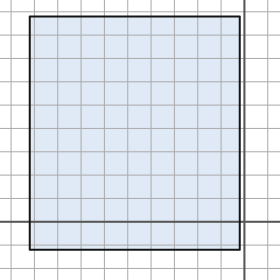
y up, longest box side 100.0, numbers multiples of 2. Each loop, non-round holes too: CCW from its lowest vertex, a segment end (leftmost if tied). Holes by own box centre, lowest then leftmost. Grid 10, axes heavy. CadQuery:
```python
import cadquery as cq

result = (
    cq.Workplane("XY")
    .moveTo(-92.0, -12.0)
    .lineTo(-2.0, -12.0)
    .lineTo(-2.0, 88.0)
    .lineTo(-92.0, 88.0)
    .close()
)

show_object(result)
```